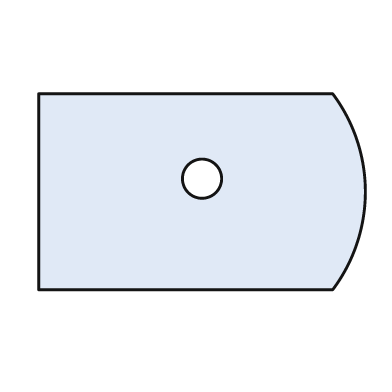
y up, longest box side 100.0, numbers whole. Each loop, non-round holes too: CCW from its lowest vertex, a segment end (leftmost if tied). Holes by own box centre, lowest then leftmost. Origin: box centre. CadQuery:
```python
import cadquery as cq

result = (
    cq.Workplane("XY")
    .moveTo(-50.0, -30.0)
    .lineTo(40.0, -30.0)
    .threePointArc((50.0, 0.0), (40.0, 30.0))
    .lineTo(-50.0, 30.0)
    .close()
    .moveTo(0.0, 4.0)
    .circle(6.0)
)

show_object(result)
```